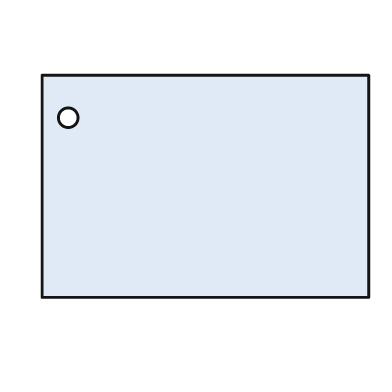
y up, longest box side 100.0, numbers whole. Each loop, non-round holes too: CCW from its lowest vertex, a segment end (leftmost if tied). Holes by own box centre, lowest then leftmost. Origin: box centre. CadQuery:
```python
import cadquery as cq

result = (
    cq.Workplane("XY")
    .moveTo(-50.0, -34.0)
    .lineTo(50.0, -34.0)
    .lineTo(50.0, 34.0)
    .lineTo(-50.0, 34.0)
    .close()
    .moveTo(-42.0, 21.0)
    .circle(3.0)
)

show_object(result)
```